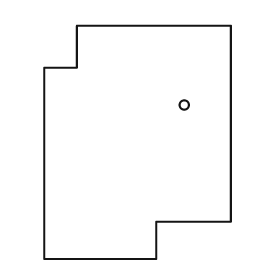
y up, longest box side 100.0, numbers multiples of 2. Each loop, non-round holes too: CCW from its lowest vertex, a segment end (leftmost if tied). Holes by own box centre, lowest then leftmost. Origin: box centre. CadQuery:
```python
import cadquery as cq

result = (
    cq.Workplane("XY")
    .moveTo(-40.0, -50.0)
    .lineTo(8.0, -50.0)
    .lineTo(8.0, -34.0)
    .lineTo(40.0, -34.0)
    .lineTo(40.0, 50.0)
    .lineTo(-26.0, 50.0)
    .lineTo(-26.0, 32.0)
    .lineTo(-40.0, 32.0)
    .close()
    .moveTo(20.0, 16.0)
    .circle(2.0)
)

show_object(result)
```